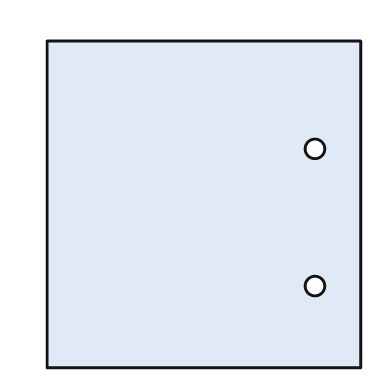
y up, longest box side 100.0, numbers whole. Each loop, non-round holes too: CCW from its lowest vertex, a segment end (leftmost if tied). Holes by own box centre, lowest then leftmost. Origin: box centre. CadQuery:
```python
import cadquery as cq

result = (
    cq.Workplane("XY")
    .moveTo(-48.0, -50.0)
    .lineTo(48.0, -50.0)
    .lineTo(48.0, 50.0)
    .lineTo(-48.0, 50.0)
    .close()
    .moveTo(34.0, -25.0)
    .circle(3.0)
    .moveTo(34.0, 17.0)
    .circle(3.0)
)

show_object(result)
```